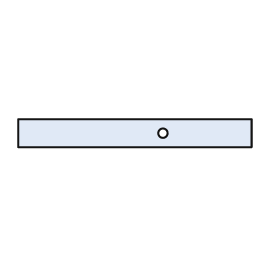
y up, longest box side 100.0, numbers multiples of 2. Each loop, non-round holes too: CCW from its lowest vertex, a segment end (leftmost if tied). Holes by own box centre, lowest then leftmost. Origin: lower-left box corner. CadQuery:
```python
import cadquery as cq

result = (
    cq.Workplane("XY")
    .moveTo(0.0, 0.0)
    .lineTo(100.0, 0.0)
    .lineTo(100.0, 12.0)
    .lineTo(0.0, 12.0)
    .close()
    .moveTo(62.0, 6.0)
    .circle(2.0)
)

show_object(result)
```